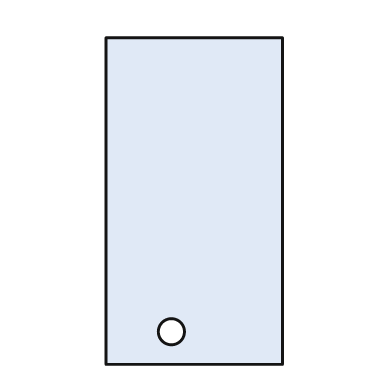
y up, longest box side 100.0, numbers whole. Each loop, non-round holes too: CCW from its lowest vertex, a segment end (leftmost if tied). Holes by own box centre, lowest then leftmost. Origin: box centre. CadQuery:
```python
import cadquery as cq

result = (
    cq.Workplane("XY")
    .moveTo(-27.0, -50.0)
    .lineTo(27.0, -50.0)
    .lineTo(27.0, 50.0)
    .lineTo(-27.0, 50.0)
    .close()
    .moveTo(-7.0, -40.0)
    .circle(4.0)
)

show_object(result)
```